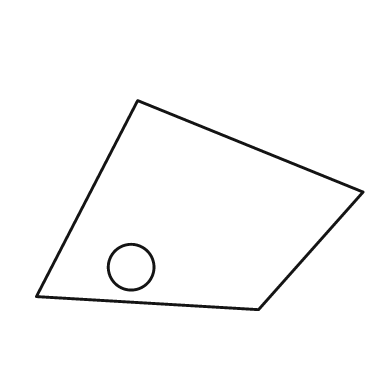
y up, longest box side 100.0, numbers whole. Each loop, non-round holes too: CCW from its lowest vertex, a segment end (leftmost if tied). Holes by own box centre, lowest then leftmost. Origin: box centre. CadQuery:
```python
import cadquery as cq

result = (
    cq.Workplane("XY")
    .moveTo(18.0, -32.0)
    .lineTo(50.0, 4.0)
    .lineTo(-19.0, 32.0)
    .lineTo(-50.0, -28.0)
    .close()
    .moveTo(-21.0, -19.0)
    .circle(7.0)
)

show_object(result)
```